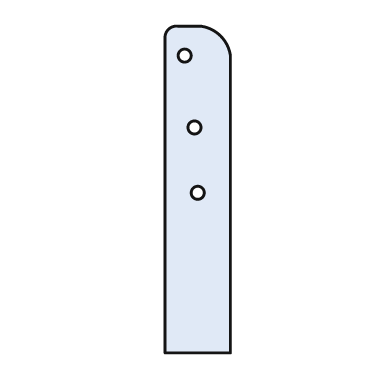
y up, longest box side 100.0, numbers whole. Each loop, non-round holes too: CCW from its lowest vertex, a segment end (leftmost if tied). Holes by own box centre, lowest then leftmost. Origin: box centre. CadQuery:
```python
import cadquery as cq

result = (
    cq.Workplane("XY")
    .moveTo(-10.0, -50.0)
    .lineTo(10.0, -50.0)
    .lineTo(10.0, 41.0)
    .threePointArc((7.0, 47.0), (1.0, 50.0))
    .lineTo(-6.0, 50.0)
    .threePointArc((-9.0, 49.0), (-10.0, 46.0))
    .close()
    .moveTo(0.0, -1.0)
    .circle(2.0)
    .moveTo(-1.0, 19.0)
    .circle(2.0)
    .moveTo(-4.0, 41.0)
    .circle(2.0)
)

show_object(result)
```